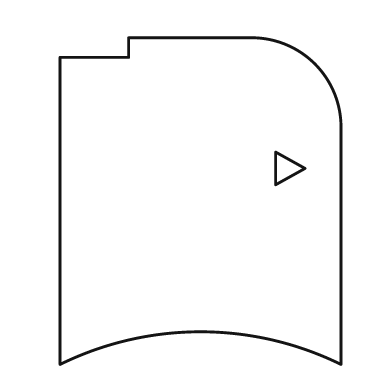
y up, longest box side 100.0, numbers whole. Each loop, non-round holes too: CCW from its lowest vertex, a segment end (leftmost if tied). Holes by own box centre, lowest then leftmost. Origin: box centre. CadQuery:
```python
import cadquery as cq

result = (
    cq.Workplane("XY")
    .moveTo(-43.0, -50.0)
    .threePointArc((0.0, -40.0), (43.0, -50.0))
    .lineTo(43.0, 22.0)
    .threePointArc((35.0, 42.0), (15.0, 50.0))
    .lineTo(-22.0, 50.0)
    .lineTo(-22.0, 44.0)
    .lineTo(-43.0, 44.0)
    .close()
    .moveTo(23.0, 5.0)
    .lineTo(32.0, 10.0)
    .lineTo(23.0, 15.0)
    .close()
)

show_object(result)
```